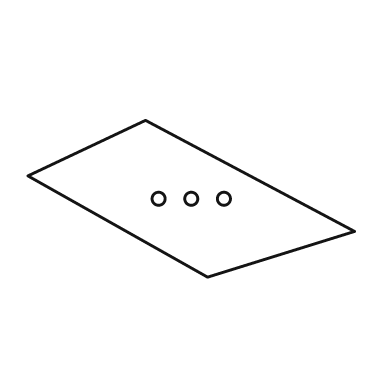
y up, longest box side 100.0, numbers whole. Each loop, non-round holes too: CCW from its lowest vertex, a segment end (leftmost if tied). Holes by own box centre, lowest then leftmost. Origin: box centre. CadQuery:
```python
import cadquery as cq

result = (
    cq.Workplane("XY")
    .moveTo(5.0, -24.0)
    .lineTo(50.0, -10.0)
    .lineTo(-14.0, 24.0)
    .lineTo(-50.0, 7.0)
    .close()
    .moveTo(-10.0, 0.0)
    .circle(2.0)
    .moveTo(0.0, 0.0)
    .circle(2.0)
    .moveTo(10.0, 0.0)
    .circle(2.0)
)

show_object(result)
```